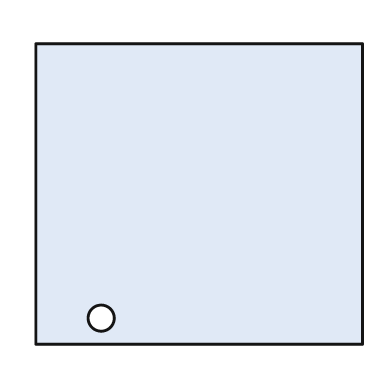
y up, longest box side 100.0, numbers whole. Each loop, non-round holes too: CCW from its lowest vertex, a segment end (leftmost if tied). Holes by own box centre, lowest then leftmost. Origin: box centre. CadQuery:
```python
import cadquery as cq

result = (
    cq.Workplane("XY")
    .moveTo(-50.0, -46.0)
    .lineTo(50.0, -46.0)
    .lineTo(50.0, 46.0)
    .lineTo(-50.0, 46.0)
    .close()
    .moveTo(-30.0, -38.0)
    .circle(4.0)
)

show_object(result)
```